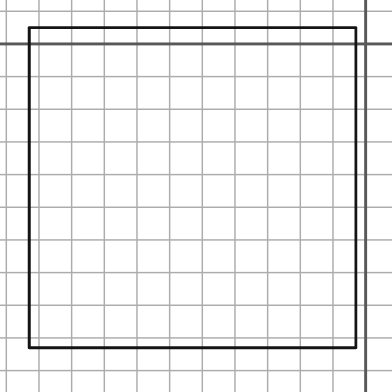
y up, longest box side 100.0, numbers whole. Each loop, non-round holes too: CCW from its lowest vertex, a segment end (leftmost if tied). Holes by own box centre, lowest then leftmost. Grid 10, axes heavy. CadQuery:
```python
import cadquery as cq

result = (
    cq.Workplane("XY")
    .moveTo(-103.0, -93.0)
    .lineTo(-3.0, -93.0)
    .lineTo(-3.0, 5.0)
    .lineTo(-103.0, 5.0)
    .close()
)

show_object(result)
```